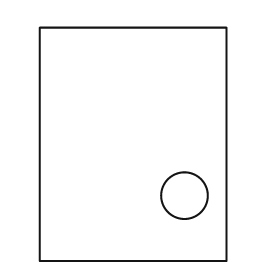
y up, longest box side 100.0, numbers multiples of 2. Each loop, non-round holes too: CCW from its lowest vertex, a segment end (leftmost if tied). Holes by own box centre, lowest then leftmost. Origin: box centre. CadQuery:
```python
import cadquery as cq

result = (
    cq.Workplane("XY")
    .moveTo(-40.0, -50.0)
    .lineTo(40.0, -50.0)
    .lineTo(40.0, 50.0)
    .lineTo(-40.0, 50.0)
    .close()
    .moveTo(22.0, -22.0)
    .circle(10.0)
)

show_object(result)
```